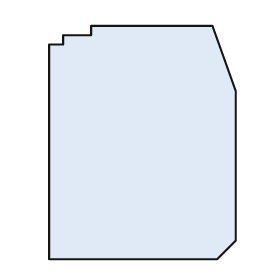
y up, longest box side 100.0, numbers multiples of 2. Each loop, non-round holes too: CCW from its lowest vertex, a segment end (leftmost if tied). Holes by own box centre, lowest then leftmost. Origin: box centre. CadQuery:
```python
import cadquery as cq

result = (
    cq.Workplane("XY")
    .moveTo(-40.0, -50.0)
    .lineTo(32.0, -50.0)
    .lineTo(40.0, -42.0)
    .lineTo(40.0, 22.0)
    .lineTo(30.0, 50.0)
    .lineTo(-22.0, 50.0)
    .lineTo(-22.0, 46.0)
    .lineTo(-34.0, 46.0)
    .lineTo(-34.0, 42.0)
    .lineTo(-40.0, 42.0)
    .close()
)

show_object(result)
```